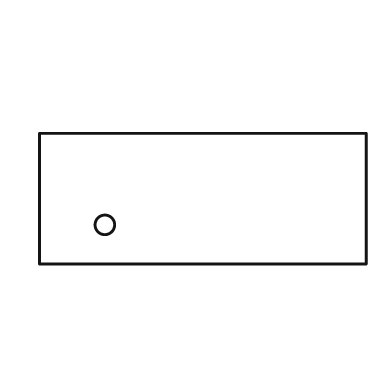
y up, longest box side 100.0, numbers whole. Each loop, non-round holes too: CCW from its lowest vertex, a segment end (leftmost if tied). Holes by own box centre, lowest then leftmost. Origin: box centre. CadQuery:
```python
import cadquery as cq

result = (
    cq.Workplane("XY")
    .moveTo(-50.0, -20.0)
    .lineTo(50.0, -20.0)
    .lineTo(50.0, 20.0)
    .lineTo(-50.0, 20.0)
    .close()
    .moveTo(-30.0, -8.0)
    .circle(3.0)
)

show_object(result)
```